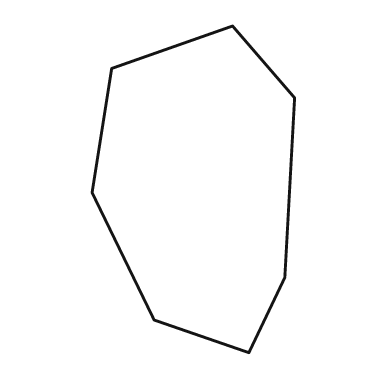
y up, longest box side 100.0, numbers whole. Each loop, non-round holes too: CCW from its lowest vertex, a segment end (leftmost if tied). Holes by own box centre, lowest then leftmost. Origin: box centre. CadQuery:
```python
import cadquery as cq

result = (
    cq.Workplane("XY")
    .moveTo(17.0, -50.0)
    .lineTo(28.0, -27.0)
    .lineTo(31.0, 28.0)
    .lineTo(12.0, 50.0)
    .lineTo(-25.0, 37.0)
    .lineTo(-31.0, -1.0)
    .lineTo(-12.0, -40.0)
    .close()
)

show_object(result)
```